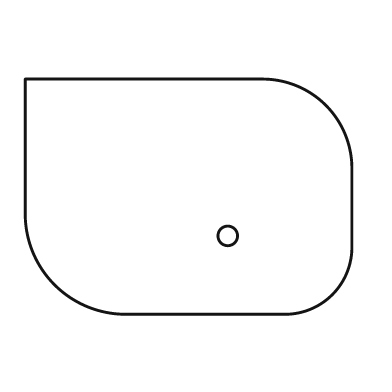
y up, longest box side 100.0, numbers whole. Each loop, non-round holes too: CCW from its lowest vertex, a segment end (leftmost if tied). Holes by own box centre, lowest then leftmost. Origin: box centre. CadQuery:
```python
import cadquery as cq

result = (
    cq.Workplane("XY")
    .moveTo(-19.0, -36.0)
    .lineTo(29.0, -36.0)
    .threePointArc((44.0, -30.0), (50.0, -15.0))
    .lineTo(50.0, 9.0)
    .threePointArc((42.0, 28.0), (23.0, 36.0))
    .lineTo(-50.0, 36.0)
    .lineTo(-50.0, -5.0)
    .threePointArc((-41.0, -27.0), (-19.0, -36.0))
    .close()
    .moveTo(12.0, -12.0)
    .circle(3.0)
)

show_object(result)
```